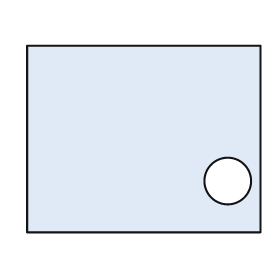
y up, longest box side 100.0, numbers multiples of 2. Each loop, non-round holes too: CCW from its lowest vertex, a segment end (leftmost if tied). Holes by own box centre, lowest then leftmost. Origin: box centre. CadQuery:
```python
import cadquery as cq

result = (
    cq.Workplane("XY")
    .moveTo(-50.0, -40.0)
    .lineTo(50.0, -40.0)
    .lineTo(50.0, 40.0)
    .lineTo(-50.0, 40.0)
    .close()
    .moveTo(36.0, -18.0)
    .circle(10.0)
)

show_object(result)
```